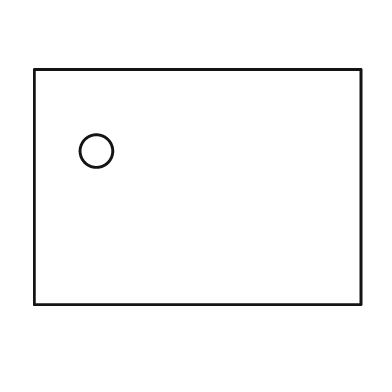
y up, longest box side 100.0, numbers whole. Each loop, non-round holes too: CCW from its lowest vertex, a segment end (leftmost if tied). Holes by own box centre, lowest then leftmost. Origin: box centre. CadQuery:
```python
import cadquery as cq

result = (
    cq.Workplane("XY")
    .moveTo(-50.0, -36.0)
    .lineTo(50.0, -36.0)
    .lineTo(50.0, 36.0)
    .lineTo(-50.0, 36.0)
    .close()
    .moveTo(-31.0, 11.0)
    .circle(5.0)
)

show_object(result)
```